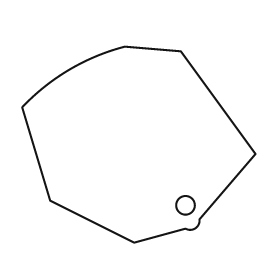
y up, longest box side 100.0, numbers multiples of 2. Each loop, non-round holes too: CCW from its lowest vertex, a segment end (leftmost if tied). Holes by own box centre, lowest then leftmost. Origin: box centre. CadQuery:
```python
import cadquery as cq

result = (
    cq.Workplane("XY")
    .moveTo(-2.0, -42.0)
    .lineTo(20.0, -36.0)
    .threePointArc((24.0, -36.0), (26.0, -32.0))
    .lineTo(50.0, -4.0)
    .lineTo(18.0, 40.0)
    .lineTo(-6.0, 42.0)
    .threePointArc((-30.0, 32.0), (-50.0, 16.0))
    .lineTo(-38.0, -24.0)
    .close()
    .moveTo(20.0, -26.0)
    .circle(4.0)
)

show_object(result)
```